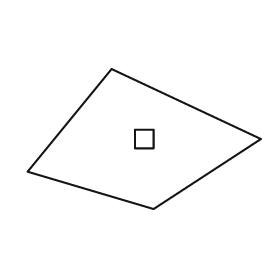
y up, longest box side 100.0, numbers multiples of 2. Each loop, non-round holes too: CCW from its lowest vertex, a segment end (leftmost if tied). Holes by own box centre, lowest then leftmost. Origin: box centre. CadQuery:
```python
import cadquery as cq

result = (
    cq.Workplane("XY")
    .moveTo(4.0, -30.0)
    .lineTo(50.0, 0.0)
    .lineTo(-14.0, 30.0)
    .lineTo(-50.0, -14.0)
    .close()
    .moveTo(-4.0, -4.0)
    .lineTo(4.0, -4.0)
    .lineTo(4.0, 4.0)
    .lineTo(-4.0, 4.0)
    .close()
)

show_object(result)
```